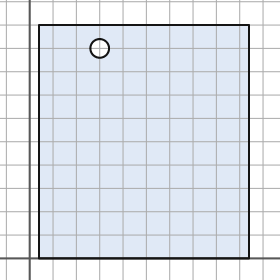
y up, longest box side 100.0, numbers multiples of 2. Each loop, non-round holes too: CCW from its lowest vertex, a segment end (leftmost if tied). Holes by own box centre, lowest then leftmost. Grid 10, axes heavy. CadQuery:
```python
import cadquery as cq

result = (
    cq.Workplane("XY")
    .moveTo(4.0, 0.0)
    .lineTo(94.0, 0.0)
    .lineTo(94.0, 100.0)
    .lineTo(4.0, 100.0)
    .close()
    .moveTo(30.0, 90.0)
    .circle(4.0)
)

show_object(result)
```